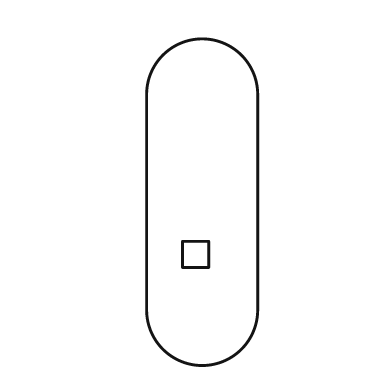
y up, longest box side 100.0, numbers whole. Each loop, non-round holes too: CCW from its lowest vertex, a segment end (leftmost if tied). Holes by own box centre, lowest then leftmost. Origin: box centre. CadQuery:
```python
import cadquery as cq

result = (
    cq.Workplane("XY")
    .moveTo(-17.0, -33.0)
    .threePointArc((0.0, -50.0), (17.0, -33.0))
    .lineTo(17.0, 33.0)
    .threePointArc((0.0, 50.0), (-17.0, 33.0))
    .close()
    .moveTo(-6.0, -20.0)
    .lineTo(2.0, -20.0)
    .lineTo(2.0, -12.0)
    .lineTo(-6.0, -12.0)
    .close()
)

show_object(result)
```